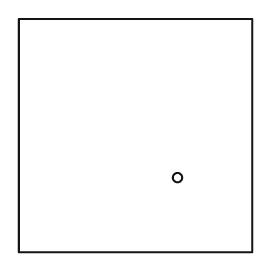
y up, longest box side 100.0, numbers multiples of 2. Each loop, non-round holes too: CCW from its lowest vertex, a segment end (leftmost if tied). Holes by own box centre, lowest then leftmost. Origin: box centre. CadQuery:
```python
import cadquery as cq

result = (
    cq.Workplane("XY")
    .moveTo(-50.0, -50.0)
    .lineTo(50.0, -50.0)
    .lineTo(50.0, 50.0)
    .lineTo(-50.0, 50.0)
    .close()
    .moveTo(18.0, -18.0)
    .circle(2.0)
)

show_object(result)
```